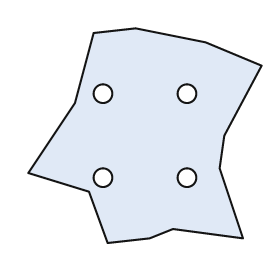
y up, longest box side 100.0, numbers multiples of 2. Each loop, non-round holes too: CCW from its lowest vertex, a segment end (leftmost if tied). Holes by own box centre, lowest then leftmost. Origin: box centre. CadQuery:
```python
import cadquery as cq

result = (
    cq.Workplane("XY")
    .moveTo(-16.0, -46.0)
    .lineTo(2.0, -44.0)
    .lineTo(12.0, -40.0)
    .lineTo(42.0, -44.0)
    .lineTo(32.0, -14.0)
    .lineTo(34.0, 0.0)
    .lineTo(50.0, 30.0)
    .lineTo(26.0, 40.0)
    .lineTo(-4.0, 46.0)
    .lineTo(-22.0, 44.0)
    .lineTo(-30.0, 14.0)
    .lineTo(-50.0, -16.0)
    .lineTo(-24.0, -24.0)
    .close()
    .moveTo(-18.0, -18.0)
    .circle(4.0)
    .moveTo(18.0, -18.0)
    .circle(4.0)
    .moveTo(-18.0, 18.0)
    .circle(4.0)
    .moveTo(18.0, 18.0)
    .circle(4.0)
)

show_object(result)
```